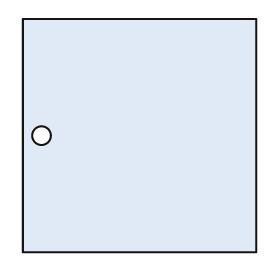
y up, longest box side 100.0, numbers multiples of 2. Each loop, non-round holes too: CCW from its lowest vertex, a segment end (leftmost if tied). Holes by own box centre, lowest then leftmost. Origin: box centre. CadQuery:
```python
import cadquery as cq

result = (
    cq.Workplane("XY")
    .moveTo(-50.0, -50.0)
    .lineTo(50.0, -50.0)
    .lineTo(50.0, 50.0)
    .lineTo(-50.0, 50.0)
    .close()
    .moveTo(-42.0, 0.0)
    .circle(4.0)
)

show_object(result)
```